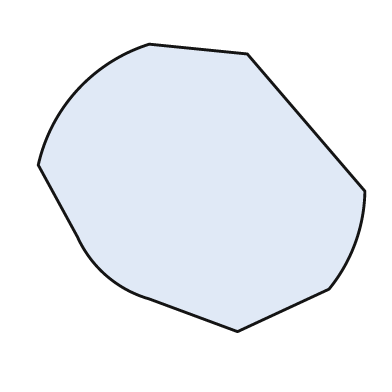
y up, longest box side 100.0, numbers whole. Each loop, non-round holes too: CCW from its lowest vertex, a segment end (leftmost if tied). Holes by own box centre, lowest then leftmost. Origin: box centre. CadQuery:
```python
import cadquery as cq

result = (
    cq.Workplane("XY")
    .moveTo(11.0, -44.0)
    .lineTo(39.0, -31.0)
    .threePointArc((47.0, -17.0), (50.0, -1.0))
    .lineTo(14.0, 41.0)
    .lineTo(-16.0, 44.0)
    .threePointArc((-38.0, 30.0), (-50.0, 7.0))
    .lineTo(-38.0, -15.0)
    .threePointArc((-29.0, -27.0), (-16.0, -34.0))
    .close()
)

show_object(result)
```